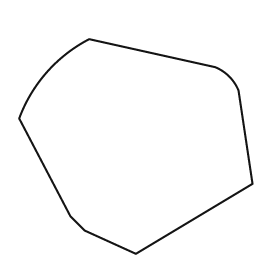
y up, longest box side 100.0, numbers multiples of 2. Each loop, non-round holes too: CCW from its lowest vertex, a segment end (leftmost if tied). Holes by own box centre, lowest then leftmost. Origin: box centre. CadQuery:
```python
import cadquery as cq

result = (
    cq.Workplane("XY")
    .moveTo(0.0, -46.0)
    .lineTo(50.0, -16.0)
    .lineTo(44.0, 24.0)
    .threePointArc((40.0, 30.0), (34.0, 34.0))
    .lineTo(-20.0, 46.0)
    .threePointArc((-38.0, 32.0), (-50.0, 12.0))
    .lineTo(-28.0, -30.0)
    .lineTo(-22.0, -36.0)
    .close()
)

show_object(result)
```